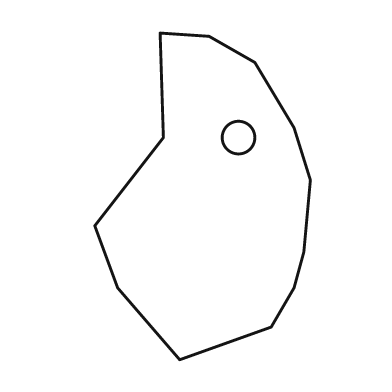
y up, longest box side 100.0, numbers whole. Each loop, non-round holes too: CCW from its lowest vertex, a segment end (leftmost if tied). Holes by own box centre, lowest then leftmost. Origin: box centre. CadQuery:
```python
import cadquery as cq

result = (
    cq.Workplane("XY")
    .moveTo(-7.0, -50.0)
    .lineTo(21.0, -40.0)
    .lineTo(28.0, -28.0)
    .lineTo(31.0, -17.0)
    .lineTo(33.0, 5.0)
    .lineTo(28.0, 21.0)
    .lineTo(16.0, 41.0)
    .lineTo(2.0, 49.0)
    .lineTo(-13.0, 50.0)
    .lineTo(-12.0, 18.0)
    .lineTo(-33.0, -9.0)
    .lineTo(-26.0, -28.0)
    .close()
    .moveTo(11.0, 18.0)
    .circle(5.0)
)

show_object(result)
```